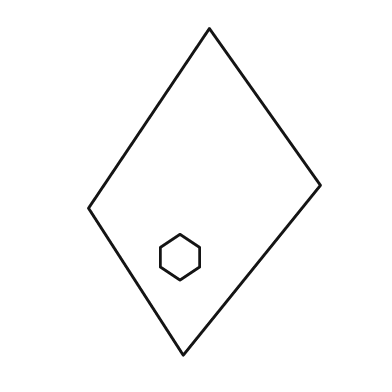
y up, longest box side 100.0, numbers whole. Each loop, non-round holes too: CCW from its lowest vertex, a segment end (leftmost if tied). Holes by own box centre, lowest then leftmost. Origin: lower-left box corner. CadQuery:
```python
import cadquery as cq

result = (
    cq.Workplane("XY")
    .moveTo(29.0, 0.0)
    .lineTo(71.0, 52.0)
    .lineTo(37.0, 100.0)
    .lineTo(0.0, 45.0)
    .close()
    .moveTo(28.0, 23.0)
    .lineTo(34.0, 27.0)
    .lineTo(34.0, 33.0)
    .lineTo(28.0, 37.0)
    .lineTo(22.0, 33.0)
    .lineTo(22.0, 27.0)
    .close()
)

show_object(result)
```